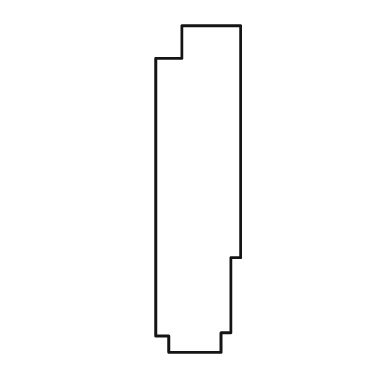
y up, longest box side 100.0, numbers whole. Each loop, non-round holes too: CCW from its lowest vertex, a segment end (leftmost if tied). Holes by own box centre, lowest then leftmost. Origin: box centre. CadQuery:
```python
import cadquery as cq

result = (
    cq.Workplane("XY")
    .moveTo(-9.0, -50.0)
    .lineTo(7.0, -50.0)
    .lineTo(7.0, -44.0)
    .lineTo(10.0, -44.0)
    .lineTo(10.0, -21.0)
    .lineTo(13.0, -21.0)
    .lineTo(13.0, 50.0)
    .lineTo(-5.0, 50.0)
    .lineTo(-5.0, 40.0)
    .lineTo(-13.0, 40.0)
    .lineTo(-13.0, -45.0)
    .lineTo(-9.0, -45.0)
    .close()
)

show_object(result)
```